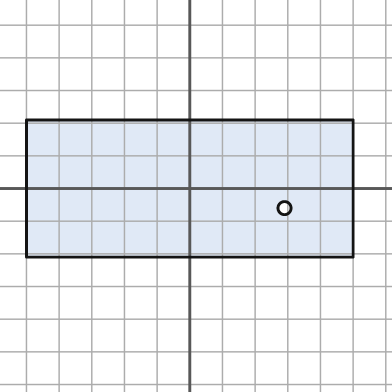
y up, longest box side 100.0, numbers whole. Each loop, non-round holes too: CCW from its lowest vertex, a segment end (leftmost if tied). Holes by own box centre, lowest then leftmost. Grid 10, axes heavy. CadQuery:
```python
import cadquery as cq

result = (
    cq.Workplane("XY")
    .moveTo(-50.0, -21.0)
    .lineTo(50.0, -21.0)
    .lineTo(50.0, 21.0)
    .lineTo(-50.0, 21.0)
    .close()
    .moveTo(29.0, -6.0)
    .circle(2.0)
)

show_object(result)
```